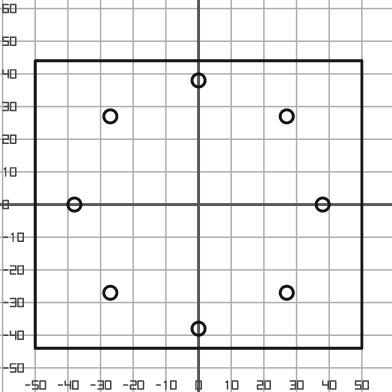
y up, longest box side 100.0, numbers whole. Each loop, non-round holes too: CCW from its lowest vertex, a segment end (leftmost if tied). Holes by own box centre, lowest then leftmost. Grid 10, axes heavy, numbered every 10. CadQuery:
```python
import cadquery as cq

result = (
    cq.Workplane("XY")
    .moveTo(-50.0, -44.0)
    .lineTo(50.0, -44.0)
    .lineTo(50.0, 44.0)
    .lineTo(-50.0, 44.0)
    .close()
    .moveTo(0.0, -38.0)
    .circle(2.0)
    .moveTo(-27.0, -27.0)
    .circle(2.0)
    .moveTo(27.0, -27.0)
    .circle(2.0)
    .moveTo(-38.0, 0.0)
    .circle(2.0)
    .moveTo(38.0, 0.0)
    .circle(2.0)
    .moveTo(-27.0, 27.0)
    .circle(2.0)
    .moveTo(27.0, 27.0)
    .circle(2.0)
    .moveTo(0.0, 38.0)
    .circle(2.0)
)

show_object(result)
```